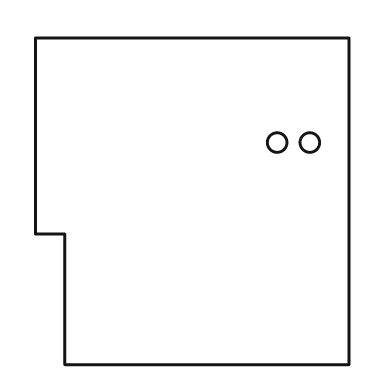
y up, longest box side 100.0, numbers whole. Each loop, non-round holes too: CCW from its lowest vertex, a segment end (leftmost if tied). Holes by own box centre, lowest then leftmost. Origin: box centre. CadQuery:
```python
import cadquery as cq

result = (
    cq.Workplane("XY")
    .moveTo(-39.0, -50.0)
    .lineTo(48.0, -50.0)
    .lineTo(48.0, 50.0)
    .lineTo(-48.0, 50.0)
    .lineTo(-48.0, -10.0)
    .lineTo(-39.0, -10.0)
    .close()
    .moveTo(26.0, 18.0)
    .circle(3.0)
    .moveTo(36.0, 18.0)
    .circle(3.0)
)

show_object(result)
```